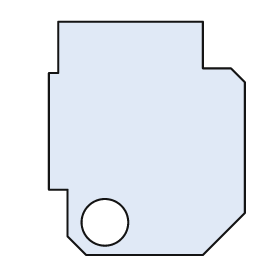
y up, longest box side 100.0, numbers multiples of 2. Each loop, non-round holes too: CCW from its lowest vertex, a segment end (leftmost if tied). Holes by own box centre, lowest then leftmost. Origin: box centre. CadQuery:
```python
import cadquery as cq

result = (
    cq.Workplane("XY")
    .moveTo(-26.0, -50.0)
    .lineTo(24.0, -50.0)
    .lineTo(42.0, -32.0)
    .lineTo(42.0, 24.0)
    .lineTo(36.0, 30.0)
    .lineTo(24.0, 30.0)
    .lineTo(24.0, 50.0)
    .lineTo(-38.0, 50.0)
    .lineTo(-38.0, 28.0)
    .lineTo(-42.0, 28.0)
    .lineTo(-42.0, -22.0)
    .lineTo(-34.0, -22.0)
    .lineTo(-34.0, -42.0)
    .close()
    .moveTo(-18.0, -36.0)
    .circle(10.0)
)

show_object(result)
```